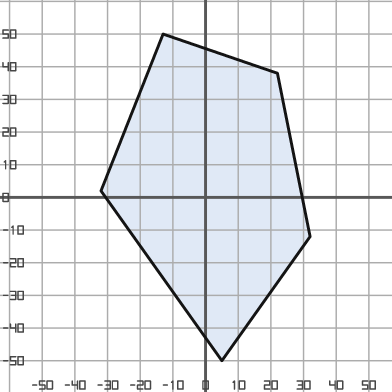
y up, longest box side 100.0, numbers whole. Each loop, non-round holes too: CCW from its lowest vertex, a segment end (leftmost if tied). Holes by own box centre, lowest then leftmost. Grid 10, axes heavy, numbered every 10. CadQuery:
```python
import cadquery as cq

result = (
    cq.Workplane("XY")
    .moveTo(5.0, -50.0)
    .lineTo(32.0, -12.0)
    .lineTo(22.0, 38.0)
    .lineTo(-13.0, 50.0)
    .lineTo(-32.0, 2.0)
    .close()
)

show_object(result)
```